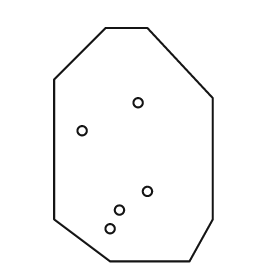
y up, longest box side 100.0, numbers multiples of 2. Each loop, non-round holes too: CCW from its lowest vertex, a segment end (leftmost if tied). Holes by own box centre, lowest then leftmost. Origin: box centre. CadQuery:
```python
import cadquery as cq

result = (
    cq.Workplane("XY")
    .moveTo(-10.0, -50.0)
    .lineTo(24.0, -50.0)
    .lineTo(34.0, -32.0)
    .lineTo(34.0, 20.0)
    .lineTo(6.0, 50.0)
    .lineTo(-12.0, 50.0)
    .lineTo(-34.0, 28.0)
    .lineTo(-34.0, -32.0)
    .close()
    .moveTo(-10.0, -36.0)
    .circle(2.0)
    .moveTo(-6.0, -28.0)
    .circle(2.0)
    .moveTo(6.0, -20.0)
    .circle(2.0)
    .moveTo(-22.0, 6.0)
    .circle(2.0)
    .moveTo(2.0, 18.0)
    .circle(2.0)
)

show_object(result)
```